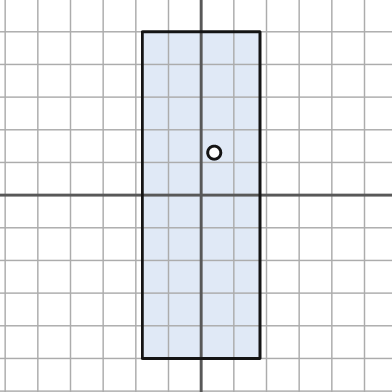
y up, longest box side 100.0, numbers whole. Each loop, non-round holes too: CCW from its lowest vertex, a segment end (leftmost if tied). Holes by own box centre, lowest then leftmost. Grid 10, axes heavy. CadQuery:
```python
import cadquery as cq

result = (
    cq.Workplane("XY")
    .moveTo(-18.0, -50.0)
    .lineTo(18.0, -50.0)
    .lineTo(18.0, 50.0)
    .lineTo(-18.0, 50.0)
    .close()
    .moveTo(4.0, 13.0)
    .circle(2.0)
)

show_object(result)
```